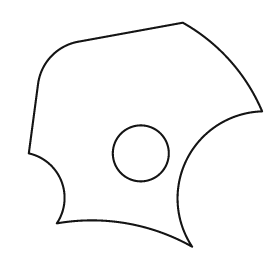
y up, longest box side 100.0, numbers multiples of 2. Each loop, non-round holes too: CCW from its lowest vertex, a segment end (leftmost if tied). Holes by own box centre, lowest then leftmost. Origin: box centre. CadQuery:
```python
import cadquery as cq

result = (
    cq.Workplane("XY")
    .moveTo(20.0, -48.0)
    .threePointArc((18.0, -10.0), (50.0, 10.0))
    .threePointArc((36.0, 32.0), (16.0, 48.0))
    .lineTo(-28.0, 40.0)
    .threePointArc((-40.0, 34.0), (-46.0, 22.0))
    .lineTo(-50.0, -8.0)
    .threePointArc((-36.0, -20.0), (-38.0, -38.0))
    .threePointArc((-8.0, -38.0), (20.0, -48.0))
    .close()
    .moveTo(-2.0, -8.0)
    .circle(12.0)
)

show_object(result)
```